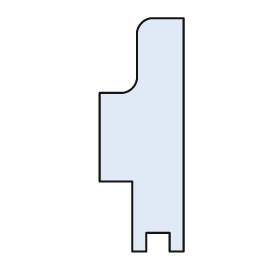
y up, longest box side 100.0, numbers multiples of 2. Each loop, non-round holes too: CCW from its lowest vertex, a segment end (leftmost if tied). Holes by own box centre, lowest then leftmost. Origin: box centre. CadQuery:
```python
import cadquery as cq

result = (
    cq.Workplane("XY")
    .moveTo(-4.0, -50.0)
    .lineTo(2.0, -50.0)
    .lineTo(2.0, -42.0)
    .lineTo(12.0, -42.0)
    .lineTo(12.0, -50.0)
    .lineTo(18.0, -50.0)
    .lineTo(18.0, 50.0)
    .lineTo(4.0, 50.0)
    .threePointArc((0.0, 48.0), (-2.0, 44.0))
    .lineTo(-2.0, 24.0)
    .threePointArc((-4.0, 20.0), (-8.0, 18.0))
    .lineTo(-18.0, 18.0)
    .lineTo(-18.0, -20.0)
    .lineTo(-4.0, -20.0)
    .close()
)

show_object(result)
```